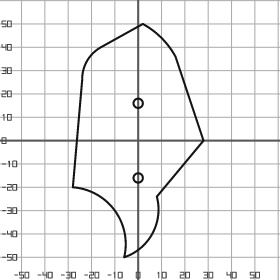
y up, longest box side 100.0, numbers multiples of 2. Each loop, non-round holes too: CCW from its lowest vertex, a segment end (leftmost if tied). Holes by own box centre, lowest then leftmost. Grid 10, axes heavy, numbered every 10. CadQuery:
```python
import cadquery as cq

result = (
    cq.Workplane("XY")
    .moveTo(-6.0, -50.0)
    .threePointArc((6.0, -40.0), (8.0, -24.0))
    .lineTo(28.0, 0.0)
    .lineTo(16.0, 36.0)
    .threePointArc((10.0, 44.0), (2.0, 50.0))
    .lineTo(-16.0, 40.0)
    .threePointArc((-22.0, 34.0), (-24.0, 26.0))
    .lineTo(-28.0, -20.0)
    .threePointArc((-10.0, -30.0), (-6.0, -50.0))
    .close()
    .moveTo(0.0, -16.0)
    .circle(2.0)
    .moveTo(0.0, 16.0)
    .circle(2.0)
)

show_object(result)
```